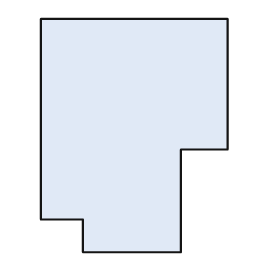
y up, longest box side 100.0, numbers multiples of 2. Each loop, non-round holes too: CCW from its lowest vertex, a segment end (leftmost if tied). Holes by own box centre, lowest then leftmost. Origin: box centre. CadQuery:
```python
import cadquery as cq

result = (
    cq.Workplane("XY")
    .moveTo(-22.0, -50.0)
    .lineTo(20.0, -50.0)
    .lineTo(20.0, -6.0)
    .lineTo(40.0, -6.0)
    .lineTo(40.0, 50.0)
    .lineTo(-40.0, 50.0)
    .lineTo(-40.0, -36.0)
    .lineTo(-22.0, -36.0)
    .close()
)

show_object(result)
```